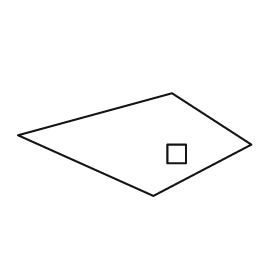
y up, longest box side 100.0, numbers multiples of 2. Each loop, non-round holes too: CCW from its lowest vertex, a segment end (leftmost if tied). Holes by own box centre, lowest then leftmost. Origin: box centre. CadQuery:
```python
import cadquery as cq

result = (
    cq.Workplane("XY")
    .moveTo(8.0, -22.0)
    .lineTo(50.0, 0.0)
    .lineTo(16.0, 22.0)
    .lineTo(-50.0, 4.0)
    .close()
    .moveTo(14.0, -8.0)
    .lineTo(22.0, -8.0)
    .lineTo(22.0, 0.0)
    .lineTo(14.0, 0.0)
    .close()
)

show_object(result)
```